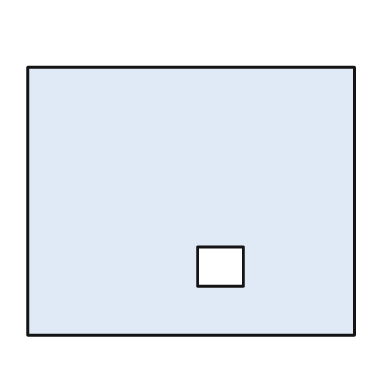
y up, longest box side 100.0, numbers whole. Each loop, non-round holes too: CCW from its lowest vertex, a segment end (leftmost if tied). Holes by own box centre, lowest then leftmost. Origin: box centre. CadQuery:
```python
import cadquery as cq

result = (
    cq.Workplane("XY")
    .moveTo(-50.0, -41.0)
    .lineTo(50.0, -41.0)
    .lineTo(50.0, 41.0)
    .lineTo(-50.0, 41.0)
    .close()
    .moveTo(2.0, -26.0)
    .lineTo(16.0, -26.0)
    .lineTo(16.0, -14.0)
    .lineTo(2.0, -14.0)
    .close()
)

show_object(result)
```